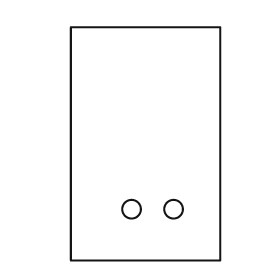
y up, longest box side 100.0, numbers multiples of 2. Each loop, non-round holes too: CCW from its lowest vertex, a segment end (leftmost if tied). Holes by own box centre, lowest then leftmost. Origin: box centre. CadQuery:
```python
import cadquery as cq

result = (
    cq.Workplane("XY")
    .moveTo(-32.0, -50.0)
    .lineTo(32.0, -50.0)
    .lineTo(32.0, 50.0)
    .lineTo(-32.0, 50.0)
    .close()
    .moveTo(-6.0, -28.0)
    .circle(4.0)
    .moveTo(12.0, -28.0)
    .circle(4.0)
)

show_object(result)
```